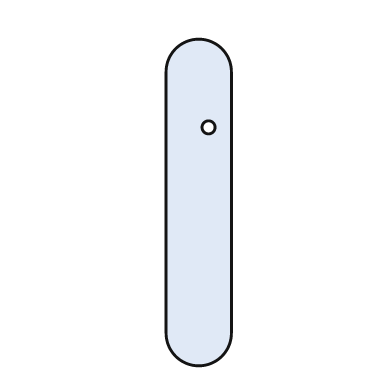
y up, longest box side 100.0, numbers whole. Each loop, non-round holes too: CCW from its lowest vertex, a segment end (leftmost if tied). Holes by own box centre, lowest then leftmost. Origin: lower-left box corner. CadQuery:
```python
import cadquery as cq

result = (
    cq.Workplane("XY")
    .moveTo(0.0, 10.0)
    .threePointArc((10.0, 0.0), (20.0, 10.0))
    .lineTo(20.0, 90.0)
    .threePointArc((10.0, 100.0), (0.0, 90.0))
    .close()
    .moveTo(13.0, 73.0)
    .circle(2.0)
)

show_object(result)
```